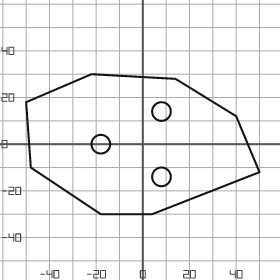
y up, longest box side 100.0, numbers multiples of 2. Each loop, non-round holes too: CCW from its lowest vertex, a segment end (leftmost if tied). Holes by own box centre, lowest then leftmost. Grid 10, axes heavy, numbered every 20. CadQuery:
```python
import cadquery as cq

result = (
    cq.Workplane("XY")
    .moveTo(-18.0, -30.0)
    .lineTo(4.0, -30.0)
    .lineTo(50.0, -12.0)
    .lineTo(40.0, 12.0)
    .lineTo(14.0, 28.0)
    .lineTo(-22.0, 30.0)
    .lineTo(-50.0, 18.0)
    .lineTo(-48.0, -10.0)
    .close()
    .moveTo(8.0, -14.0)
    .circle(4.0)
    .moveTo(-18.0, 0.0)
    .circle(4.0)
    .moveTo(8.0, 14.0)
    .circle(4.0)
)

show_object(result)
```